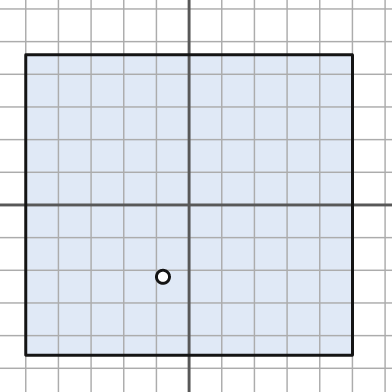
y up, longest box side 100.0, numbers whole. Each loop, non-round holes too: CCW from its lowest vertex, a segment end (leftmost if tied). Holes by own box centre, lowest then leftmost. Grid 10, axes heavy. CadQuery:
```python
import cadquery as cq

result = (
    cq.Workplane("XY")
    .moveTo(-50.0, -46.0)
    .lineTo(50.0, -46.0)
    .lineTo(50.0, 46.0)
    .lineTo(-50.0, 46.0)
    .close()
    .moveTo(-8.0, -22.0)
    .circle(2.0)
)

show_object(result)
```